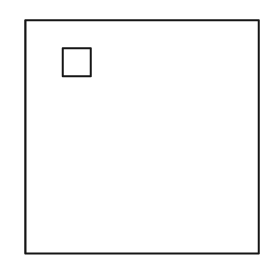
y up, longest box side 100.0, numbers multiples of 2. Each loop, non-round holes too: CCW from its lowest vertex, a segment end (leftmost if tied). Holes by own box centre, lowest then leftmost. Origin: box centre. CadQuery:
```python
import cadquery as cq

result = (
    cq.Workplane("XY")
    .moveTo(-50.0, -50.0)
    .lineTo(50.0, -50.0)
    .lineTo(50.0, 50.0)
    .lineTo(-50.0, 50.0)
    .close()
    .moveTo(-34.0, 26.0)
    .lineTo(-22.0, 26.0)
    .lineTo(-22.0, 38.0)
    .lineTo(-34.0, 38.0)
    .close()
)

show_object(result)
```